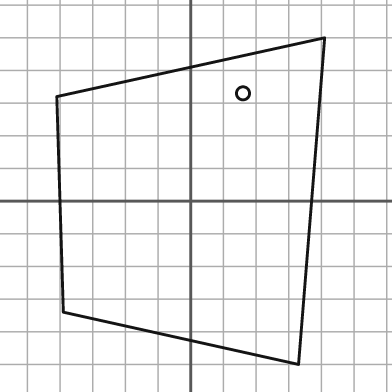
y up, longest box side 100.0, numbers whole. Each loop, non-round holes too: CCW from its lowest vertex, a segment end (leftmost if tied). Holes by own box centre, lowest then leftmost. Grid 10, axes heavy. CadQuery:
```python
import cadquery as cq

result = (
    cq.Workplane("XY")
    .moveTo(33.0, -50.0)
    .lineTo(41.0, 50.0)
    .lineTo(-41.0, 32.0)
    .lineTo(-39.0, -34.0)
    .close()
    .moveTo(16.0, 33.0)
    .circle(2.0)
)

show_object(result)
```